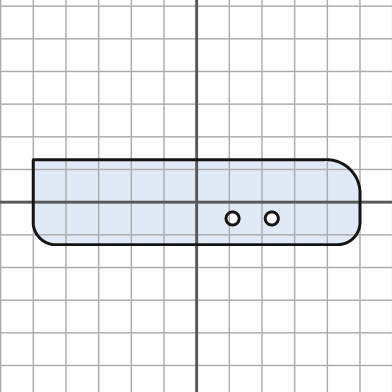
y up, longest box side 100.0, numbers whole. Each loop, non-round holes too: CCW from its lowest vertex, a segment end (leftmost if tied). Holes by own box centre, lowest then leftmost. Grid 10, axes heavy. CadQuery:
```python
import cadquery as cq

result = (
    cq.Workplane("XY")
    .moveTo(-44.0, -13.0)
    .lineTo(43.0, -13.0)
    .threePointArc((48.0, -11.0), (50.0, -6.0))
    .lineTo(50.0, 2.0)
    .threePointArc((47.0, 10.0), (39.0, 13.0))
    .lineTo(-50.0, 13.0)
    .lineTo(-50.0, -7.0)
    .threePointArc((-48.0, -11.0), (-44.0, -13.0))
    .close()
    .moveTo(11.0, -5.0)
    .circle(2.0)
    .moveTo(23.0, -5.0)
    .circle(2.0)
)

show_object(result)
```